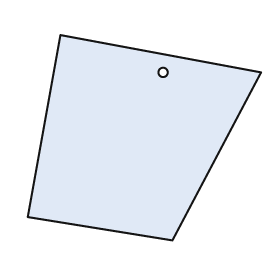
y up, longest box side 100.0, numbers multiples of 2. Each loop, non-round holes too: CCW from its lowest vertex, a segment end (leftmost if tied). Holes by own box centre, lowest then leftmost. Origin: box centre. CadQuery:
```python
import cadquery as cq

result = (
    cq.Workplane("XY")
    .moveTo(12.0, -44.0)
    .lineTo(50.0, 28.0)
    .lineTo(-36.0, 44.0)
    .lineTo(-50.0, -34.0)
    .close()
    .moveTo(8.0, 28.0)
    .circle(2.0)
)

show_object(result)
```